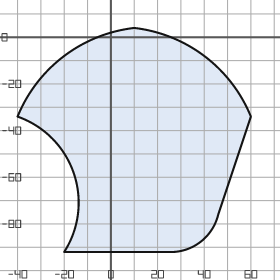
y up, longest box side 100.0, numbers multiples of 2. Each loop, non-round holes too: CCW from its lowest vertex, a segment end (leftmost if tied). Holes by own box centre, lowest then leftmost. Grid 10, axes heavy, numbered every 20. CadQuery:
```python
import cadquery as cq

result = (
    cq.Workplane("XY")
    .moveTo(-20.0, -92.0)
    .lineTo(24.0, -92.0)
    .threePointArc((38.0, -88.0), (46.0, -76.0))
    .lineTo(60.0, -34.0)
    .threePointArc((40.0, -8.0), (10.0, 4.0))
    .threePointArc((-20.0, -8.0), (-40.0, -34.0))
    .threePointArc((-16.0, -58.0), (-20.0, -92.0))
    .close()
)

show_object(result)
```